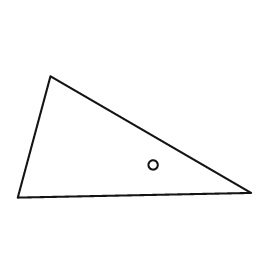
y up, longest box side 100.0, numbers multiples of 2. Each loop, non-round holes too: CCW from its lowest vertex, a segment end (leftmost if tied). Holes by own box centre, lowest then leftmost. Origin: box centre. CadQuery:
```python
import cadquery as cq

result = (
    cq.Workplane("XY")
    .moveTo(-50.0, -26.0)
    .lineTo(50.0, -24.0)
    .lineTo(-36.0, 26.0)
    .close()
    .moveTo(8.0, -12.0)
    .circle(2.0)
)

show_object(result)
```